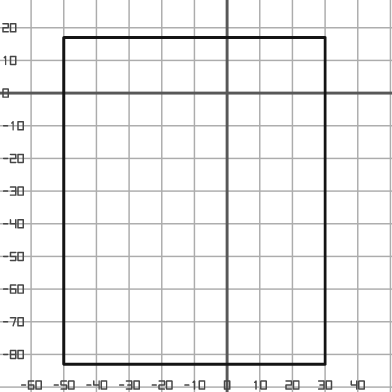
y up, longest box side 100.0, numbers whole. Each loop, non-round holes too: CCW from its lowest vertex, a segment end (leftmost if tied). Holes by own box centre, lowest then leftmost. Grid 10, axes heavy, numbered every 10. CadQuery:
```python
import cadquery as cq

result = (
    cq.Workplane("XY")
    .moveTo(-50.0, -83.0)
    .lineTo(30.0, -83.0)
    .lineTo(30.0, 17.0)
    .lineTo(-50.0, 17.0)
    .close()
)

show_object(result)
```